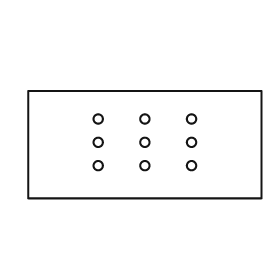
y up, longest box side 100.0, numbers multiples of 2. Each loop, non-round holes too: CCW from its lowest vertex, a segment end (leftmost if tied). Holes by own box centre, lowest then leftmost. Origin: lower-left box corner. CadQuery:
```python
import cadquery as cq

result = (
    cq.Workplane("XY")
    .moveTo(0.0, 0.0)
    .lineTo(100.0, 0.0)
    .lineTo(100.0, 46.0)
    .lineTo(0.0, 46.0)
    .close()
    .moveTo(30.0, 14.0)
    .circle(2.0)
    .moveTo(50.0, 14.0)
    .circle(2.0)
    .moveTo(70.0, 14.0)
    .circle(2.0)
    .moveTo(30.0, 24.0)
    .circle(2.0)
    .moveTo(50.0, 24.0)
    .circle(2.0)
    .moveTo(70.0, 24.0)
    .circle(2.0)
    .moveTo(30.0, 34.0)
    .circle(2.0)
    .moveTo(50.0, 34.0)
    .circle(2.0)
    .moveTo(70.0, 34.0)
    .circle(2.0)
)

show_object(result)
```